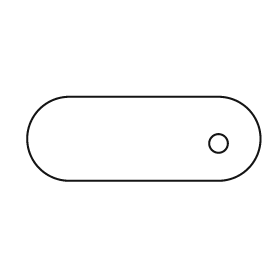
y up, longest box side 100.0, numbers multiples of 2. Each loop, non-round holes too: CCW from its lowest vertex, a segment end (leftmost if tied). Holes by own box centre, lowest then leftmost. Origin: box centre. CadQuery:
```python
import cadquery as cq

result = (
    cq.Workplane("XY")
    .moveTo(-32.0, -18.0)
    .lineTo(32.0, -18.0)
    .threePointArc((50.0, 0.0), (32.0, 18.0))
    .lineTo(-32.0, 18.0)
    .threePointArc((-50.0, 0.0), (-32.0, -18.0))
    .close()
    .moveTo(32.0, -2.0)
    .circle(4.0)
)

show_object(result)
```